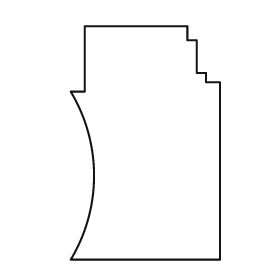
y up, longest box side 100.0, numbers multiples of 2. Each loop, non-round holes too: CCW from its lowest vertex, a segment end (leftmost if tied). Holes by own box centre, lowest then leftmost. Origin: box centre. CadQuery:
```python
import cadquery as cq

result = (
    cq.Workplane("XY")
    .moveTo(-32.0, -50.0)
    .lineTo(32.0, -50.0)
    .lineTo(32.0, 26.0)
    .lineTo(26.0, 26.0)
    .lineTo(26.0, 30.0)
    .lineTo(22.0, 30.0)
    .lineTo(22.0, 44.0)
    .lineTo(18.0, 44.0)
    .lineTo(18.0, 50.0)
    .lineTo(-26.0, 50.0)
    .lineTo(-26.0, 22.0)
    .lineTo(-32.0, 22.0)
    .threePointArc((-22.0, -14.0), (-32.0, -50.0))
    .close()
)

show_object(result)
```